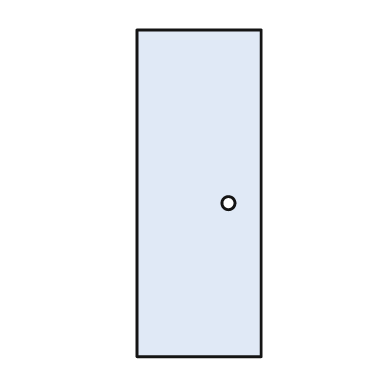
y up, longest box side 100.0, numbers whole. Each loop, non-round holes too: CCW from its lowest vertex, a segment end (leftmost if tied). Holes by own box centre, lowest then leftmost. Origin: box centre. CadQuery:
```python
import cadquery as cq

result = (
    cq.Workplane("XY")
    .moveTo(-19.0, -50.0)
    .lineTo(19.0, -50.0)
    .lineTo(19.0, 50.0)
    .lineTo(-19.0, 50.0)
    .close()
    .moveTo(9.0, -3.0)
    .circle(2.0)
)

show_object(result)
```